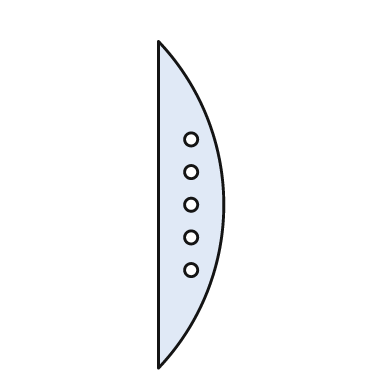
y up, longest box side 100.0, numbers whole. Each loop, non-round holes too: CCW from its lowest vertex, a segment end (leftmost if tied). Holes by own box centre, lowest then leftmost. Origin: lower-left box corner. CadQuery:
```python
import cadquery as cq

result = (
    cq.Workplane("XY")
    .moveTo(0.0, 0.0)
    .threePointArc((20.0, 50.0), (0.0, 100.0))
    .close()
    .moveTo(10.0, 30.0)
    .circle(2.0)
    .moveTo(10.0, 40.0)
    .circle(2.0)
    .moveTo(10.0, 50.0)
    .circle(2.0)
    .moveTo(10.0, 60.0)
    .circle(2.0)
    .moveTo(10.0, 70.0)
    .circle(2.0)
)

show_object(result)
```